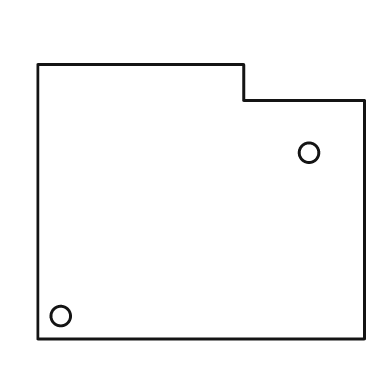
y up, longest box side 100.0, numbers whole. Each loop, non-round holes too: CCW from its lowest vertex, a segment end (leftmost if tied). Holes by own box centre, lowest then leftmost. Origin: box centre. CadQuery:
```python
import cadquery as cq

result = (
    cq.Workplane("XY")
    .moveTo(-50.0, -42.0)
    .lineTo(50.0, -42.0)
    .lineTo(50.0, 31.0)
    .lineTo(13.0, 31.0)
    .lineTo(13.0, 42.0)
    .lineTo(-50.0, 42.0)
    .close()
    .moveTo(-43.0, -35.0)
    .circle(3.0)
    .moveTo(33.0, 15.0)
    .circle(3.0)
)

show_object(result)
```